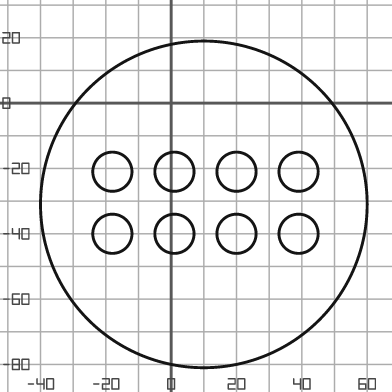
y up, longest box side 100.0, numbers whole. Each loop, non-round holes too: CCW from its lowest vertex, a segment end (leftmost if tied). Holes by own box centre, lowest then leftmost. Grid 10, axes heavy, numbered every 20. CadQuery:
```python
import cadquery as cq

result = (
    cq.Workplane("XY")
    .moveTo(10.0, -31.0)
    .circle(50.0)
    .moveTo(-18.0, -40.0)
    .circle(6.0)
    .moveTo(1.0, -40.0)
    .circle(6.0)
    .moveTo(20.0, -40.0)
    .circle(6.0)
    .moveTo(39.0, -40.0)
    .circle(6.0)
    .moveTo(-18.0, -21.0)
    .circle(6.0)
    .moveTo(1.0, -21.0)
    .circle(6.0)
    .moveTo(20.0, -21.0)
    .circle(6.0)
    .moveTo(39.0, -21.0)
    .circle(6.0)
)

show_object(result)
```